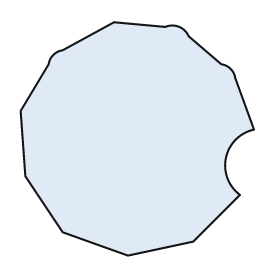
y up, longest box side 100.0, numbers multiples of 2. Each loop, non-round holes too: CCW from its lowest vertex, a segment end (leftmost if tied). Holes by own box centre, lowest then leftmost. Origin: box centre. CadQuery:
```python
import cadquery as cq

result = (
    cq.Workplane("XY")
    .moveTo(-4.0, -50.0)
    .lineTo(24.0, -44.0)
    .lineTo(44.0, -24.0)
    .threePointArc((38.0, -8.0), (50.0, 4.0))
    .lineTo(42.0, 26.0)
    .threePointArc((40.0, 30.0), (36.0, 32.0))
    .lineTo(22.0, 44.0)
    .threePointArc((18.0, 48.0), (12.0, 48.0))
    .lineTo(-10.0, 50.0)
    .lineTo(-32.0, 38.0)
    .threePointArc((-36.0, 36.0), (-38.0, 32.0))
    .lineTo(-50.0, 12.0)
    .lineTo(-48.0, -16.0)
    .lineTo(-32.0, -40.0)
    .close()
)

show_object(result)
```